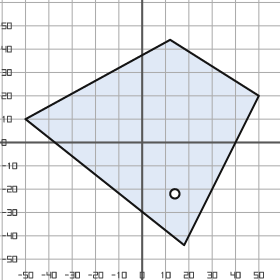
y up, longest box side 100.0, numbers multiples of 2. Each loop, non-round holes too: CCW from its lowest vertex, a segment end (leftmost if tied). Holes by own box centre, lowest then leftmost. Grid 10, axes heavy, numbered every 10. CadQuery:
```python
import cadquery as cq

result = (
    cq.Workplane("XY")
    .moveTo(18.0, -44.0)
    .lineTo(50.0, 20.0)
    .lineTo(12.0, 44.0)
    .lineTo(-50.0, 10.0)
    .close()
    .moveTo(14.0, -22.0)
    .circle(2.0)
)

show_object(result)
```